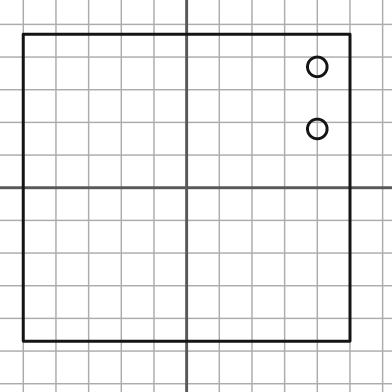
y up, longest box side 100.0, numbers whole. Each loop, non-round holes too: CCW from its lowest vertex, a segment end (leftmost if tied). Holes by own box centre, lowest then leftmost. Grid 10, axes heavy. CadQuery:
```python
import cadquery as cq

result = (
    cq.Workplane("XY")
    .moveTo(-50.0, -47.0)
    .lineTo(50.0, -47.0)
    .lineTo(50.0, 47.0)
    .lineTo(-50.0, 47.0)
    .close()
    .moveTo(40.0, 18.0)
    .circle(3.0)
    .moveTo(40.0, 37.0)
    .circle(3.0)
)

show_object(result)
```